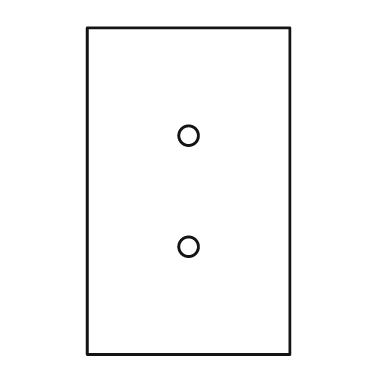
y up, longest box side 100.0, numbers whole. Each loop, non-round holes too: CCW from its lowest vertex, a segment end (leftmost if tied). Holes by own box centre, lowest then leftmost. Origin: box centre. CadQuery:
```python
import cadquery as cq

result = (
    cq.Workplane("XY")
    .moveTo(-31.0, -50.0)
    .lineTo(31.0, -50.0)
    .lineTo(31.0, 50.0)
    .lineTo(-31.0, 50.0)
    .close()
    .moveTo(0.0, -17.0)
    .circle(3.0)
    .moveTo(0.0, 17.0)
    .circle(3.0)
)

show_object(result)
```